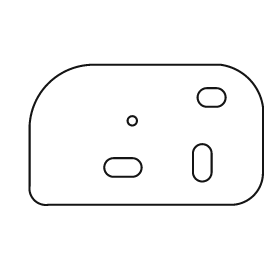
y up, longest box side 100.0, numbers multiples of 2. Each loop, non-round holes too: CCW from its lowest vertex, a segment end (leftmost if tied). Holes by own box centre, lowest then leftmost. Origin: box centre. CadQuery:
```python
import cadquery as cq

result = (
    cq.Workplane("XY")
    .moveTo(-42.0, -30.0)
    .lineTo(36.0, -30.0)
    .threePointArc((46.0, -26.0), (50.0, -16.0))
    .lineTo(50.0, 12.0)
    .threePointArc((44.0, 24.0), (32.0, 30.0))
    .lineTo(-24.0, 30.0)
    .threePointArc((-42.0, 22.0), (-50.0, 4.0))
    .lineTo(-50.0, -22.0)
    .threePointArc((-48.0, -28.0), (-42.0, -30.0))
    .close()
    .moveTo(-14.0, -18.0)
    .lineTo(-6.0, -18.0)
    .threePointArc((-2.0, -14.0), (-6.0, -10.0))
    .lineTo(-14.0, -10.0)
    .threePointArc((-18.0, -14.0), (-14.0, -18.0))
    .close()
    .moveTo(20.0, -16.0)
    .threePointArc((24.0, -20.0), (28.0, -16.0))
    .lineTo(28.0, -8.0)
    .threePointArc((24.0, -4.0), (20.0, -8.0))
    .close()
    .moveTo(-6.0, 6.0)
    .circle(2.0)
    .moveTo(26.0, 12.0)
    .lineTo(30.0, 12.0)
    .threePointArc((34.0, 16.0), (30.0, 20.0))
    .lineTo(26.0, 20.0)
    .threePointArc((22.0, 16.0), (26.0, 12.0))
    .close()
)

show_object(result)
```